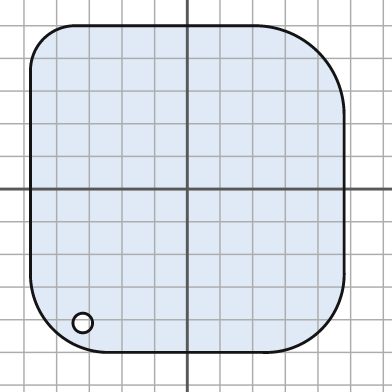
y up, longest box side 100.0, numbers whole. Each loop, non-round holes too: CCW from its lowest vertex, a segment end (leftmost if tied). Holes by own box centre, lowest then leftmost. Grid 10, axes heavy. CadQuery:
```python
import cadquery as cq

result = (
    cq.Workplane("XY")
    .moveTo(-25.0, -50.0)
    .lineTo(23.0, -50.0)
    .threePointArc((41.0, -43.0), (48.0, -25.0))
    .lineTo(48.0, 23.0)
    .threePointArc((40.0, 42.0), (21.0, 50.0))
    .lineTo(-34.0, 50.0)
    .threePointArc((-44.0, 46.0), (-48.0, 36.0))
    .lineTo(-48.0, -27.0)
    .threePointArc((-41.0, -43.0), (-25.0, -50.0))
    .close()
    .moveTo(-32.0, -41.0)
    .circle(3.0)
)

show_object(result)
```